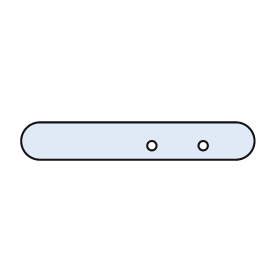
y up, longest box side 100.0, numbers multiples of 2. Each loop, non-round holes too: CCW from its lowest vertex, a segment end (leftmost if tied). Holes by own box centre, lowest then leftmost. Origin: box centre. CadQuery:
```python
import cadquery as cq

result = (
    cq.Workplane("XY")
    .moveTo(-42.0, -8.0)
    .lineTo(42.0, -8.0)
    .threePointArc((50.0, 0.0), (42.0, 8.0))
    .lineTo(-42.0, 8.0)
    .threePointArc((-50.0, 0.0), (-42.0, -8.0))
    .close()
    .moveTo(6.0, -2.0)
    .circle(2.0)
    .moveTo(28.0, -2.0)
    .circle(2.0)
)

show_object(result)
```